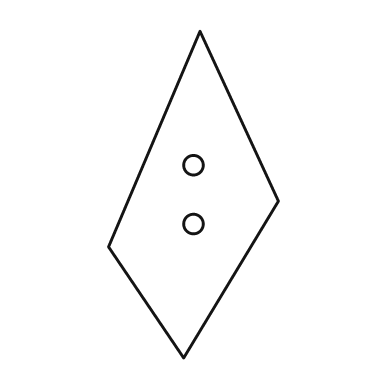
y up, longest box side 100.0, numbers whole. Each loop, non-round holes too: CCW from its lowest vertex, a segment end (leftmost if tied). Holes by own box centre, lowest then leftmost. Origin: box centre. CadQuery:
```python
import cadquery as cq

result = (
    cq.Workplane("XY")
    .moveTo(-3.0, -50.0)
    .lineTo(26.0, -2.0)
    .lineTo(2.0, 50.0)
    .lineTo(-26.0, -16.0)
    .close()
    .moveTo(0.0, -9.0)
    .circle(3.0)
    .moveTo(0.0, 9.0)
    .circle(3.0)
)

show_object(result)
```